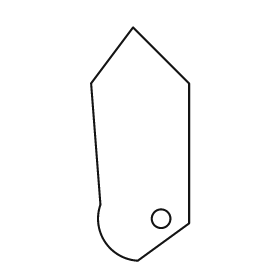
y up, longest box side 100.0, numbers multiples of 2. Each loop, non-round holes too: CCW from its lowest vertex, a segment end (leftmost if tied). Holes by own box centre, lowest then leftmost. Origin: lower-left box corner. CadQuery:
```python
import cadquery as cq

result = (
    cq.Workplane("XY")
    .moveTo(20.0, 0.0)
    .lineTo(42.0, 16.0)
    .lineTo(42.0, 76.0)
    .lineTo(18.0, 100.0)
    .lineTo(0.0, 76.0)
    .lineTo(4.0, 24.0)
    .threePointArc((6.0, 8.0), (20.0, 0.0))
    .close()
    .moveTo(30.0, 18.0)
    .circle(4.0)
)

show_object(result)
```